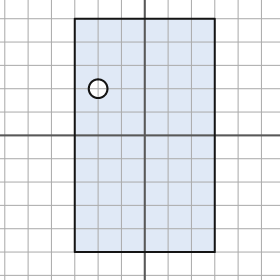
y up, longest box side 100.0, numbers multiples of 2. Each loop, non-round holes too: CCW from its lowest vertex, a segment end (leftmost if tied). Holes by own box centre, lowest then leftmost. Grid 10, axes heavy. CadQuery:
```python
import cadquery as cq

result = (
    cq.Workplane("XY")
    .moveTo(-30.0, -50.0)
    .lineTo(30.0, -50.0)
    .lineTo(30.0, 50.0)
    .lineTo(-30.0, 50.0)
    .close()
    .moveTo(-20.0, 20.0)
    .circle(4.0)
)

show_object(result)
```